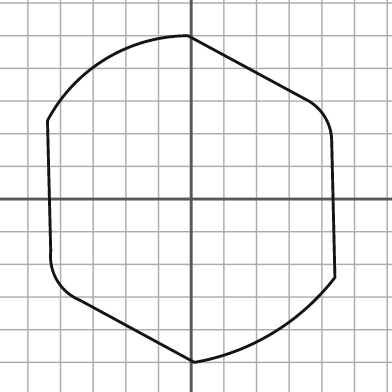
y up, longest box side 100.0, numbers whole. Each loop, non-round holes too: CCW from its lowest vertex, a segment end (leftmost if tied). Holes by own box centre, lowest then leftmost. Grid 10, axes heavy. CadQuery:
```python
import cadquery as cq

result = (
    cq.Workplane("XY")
    .moveTo(1.0, -50.0)
    .threePointArc((25.0, -41.0), (44.0, -24.0))
    .lineTo(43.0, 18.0)
    .threePointArc((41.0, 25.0), (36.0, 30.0))
    .lineTo(-1.0, 50.0)
    .threePointArc((-26.0, 43.0), (-44.0, 24.0))
    .lineTo(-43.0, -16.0)
    .threePointArc((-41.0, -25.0), (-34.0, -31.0))
    .close()
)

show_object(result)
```